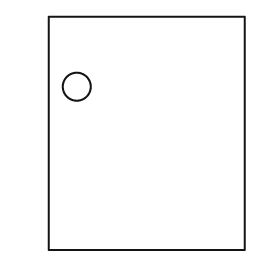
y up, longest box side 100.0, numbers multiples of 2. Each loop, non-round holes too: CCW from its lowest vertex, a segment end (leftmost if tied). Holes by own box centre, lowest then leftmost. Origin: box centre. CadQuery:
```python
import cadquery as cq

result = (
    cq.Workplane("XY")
    .moveTo(-42.0, -50.0)
    .lineTo(42.0, -50.0)
    .lineTo(42.0, 50.0)
    .lineTo(-42.0, 50.0)
    .close()
    .moveTo(-30.0, 20.0)
    .circle(6.0)
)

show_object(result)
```